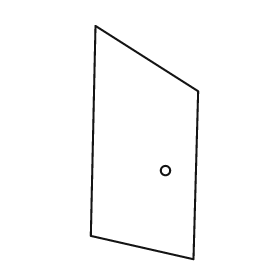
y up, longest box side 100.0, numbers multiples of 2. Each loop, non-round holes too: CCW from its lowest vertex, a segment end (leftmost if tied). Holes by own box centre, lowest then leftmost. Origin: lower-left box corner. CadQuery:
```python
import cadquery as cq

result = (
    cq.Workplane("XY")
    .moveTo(44.0, 0.0)
    .lineTo(46.0, 72.0)
    .lineTo(2.0, 100.0)
    .lineTo(0.0, 10.0)
    .close()
    .moveTo(32.0, 38.0)
    .circle(2.0)
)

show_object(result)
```